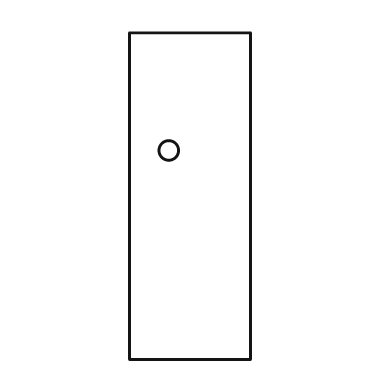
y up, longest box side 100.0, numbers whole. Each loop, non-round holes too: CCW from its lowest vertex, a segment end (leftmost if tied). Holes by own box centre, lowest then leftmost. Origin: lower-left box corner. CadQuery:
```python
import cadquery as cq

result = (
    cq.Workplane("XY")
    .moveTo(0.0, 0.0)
    .lineTo(37.0, 0.0)
    .lineTo(37.0, 100.0)
    .lineTo(0.0, 100.0)
    .close()
    .moveTo(12.0, 64.0)
    .circle(3.0)
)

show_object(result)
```